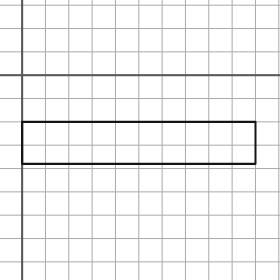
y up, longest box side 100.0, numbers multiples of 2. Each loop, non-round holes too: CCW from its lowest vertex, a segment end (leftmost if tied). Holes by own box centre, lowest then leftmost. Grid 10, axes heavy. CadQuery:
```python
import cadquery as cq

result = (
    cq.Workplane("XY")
    .moveTo(0.0, -38.0)
    .lineTo(100.0, -38.0)
    .lineTo(100.0, -20.0)
    .lineTo(0.0, -20.0)
    .close()
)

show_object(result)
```